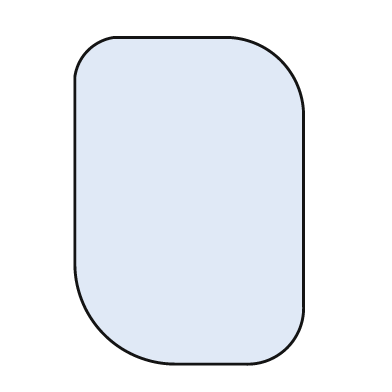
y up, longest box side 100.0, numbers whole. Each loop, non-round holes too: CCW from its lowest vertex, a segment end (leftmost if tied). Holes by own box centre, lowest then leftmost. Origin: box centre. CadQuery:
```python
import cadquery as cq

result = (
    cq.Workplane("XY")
    .moveTo(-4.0, -50.0)
    .lineTo(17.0, -50.0)
    .threePointArc((30.0, -45.0), (35.0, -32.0))
    .lineTo(35.0, 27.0)
    .threePointArc((28.0, 43.0), (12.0, 50.0))
    .lineTo(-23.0, 50.0)
    .threePointArc((-31.0, 46.0), (-35.0, 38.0))
    .lineTo(-35.0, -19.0)
    .threePointArc((-26.0, -41.0), (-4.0, -50.0))
    .close()
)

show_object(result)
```